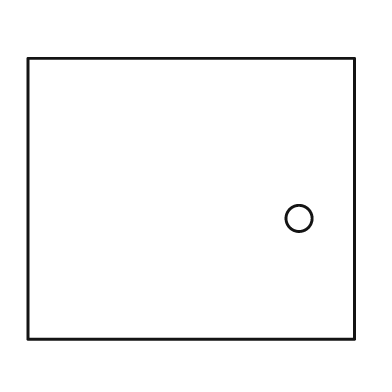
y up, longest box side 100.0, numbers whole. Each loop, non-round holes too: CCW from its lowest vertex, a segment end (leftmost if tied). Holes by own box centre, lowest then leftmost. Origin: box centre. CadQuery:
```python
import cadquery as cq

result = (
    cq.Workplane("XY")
    .moveTo(-50.0, -43.0)
    .lineTo(50.0, -43.0)
    .lineTo(50.0, 43.0)
    .lineTo(-50.0, 43.0)
    .close()
    .moveTo(33.0, -6.0)
    .circle(4.0)
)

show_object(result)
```